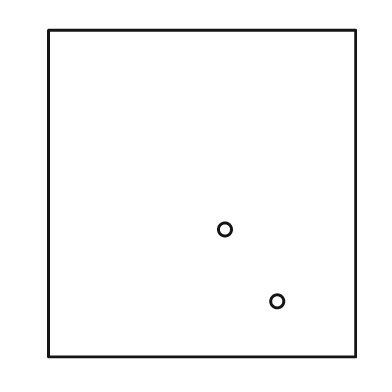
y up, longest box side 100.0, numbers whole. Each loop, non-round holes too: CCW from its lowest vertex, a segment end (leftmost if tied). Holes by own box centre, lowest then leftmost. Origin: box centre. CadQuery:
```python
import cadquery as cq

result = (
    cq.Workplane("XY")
    .moveTo(-47.0, -50.0)
    .lineTo(47.0, -50.0)
    .lineTo(47.0, 50.0)
    .lineTo(-47.0, 50.0)
    .close()
    .moveTo(23.0, -33.0)
    .circle(2.0)
    .moveTo(7.0, -11.0)
    .circle(2.0)
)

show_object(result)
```